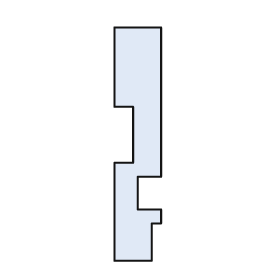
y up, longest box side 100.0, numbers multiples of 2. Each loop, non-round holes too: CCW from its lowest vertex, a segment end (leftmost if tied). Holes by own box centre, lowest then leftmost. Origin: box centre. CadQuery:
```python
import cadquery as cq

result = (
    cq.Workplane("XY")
    .moveTo(-10.0, -50.0)
    .lineTo(6.0, -50.0)
    .lineTo(6.0, -34.0)
    .lineTo(10.0, -34.0)
    .lineTo(10.0, -28.0)
    .lineTo(0.0, -28.0)
    .lineTo(0.0, -14.0)
    .lineTo(10.0, -14.0)
    .lineTo(10.0, 50.0)
    .lineTo(-10.0, 50.0)
    .lineTo(-10.0, 16.0)
    .lineTo(-2.0, 16.0)
    .lineTo(-2.0, -8.0)
    .lineTo(-10.0, -8.0)
    .close()
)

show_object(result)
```